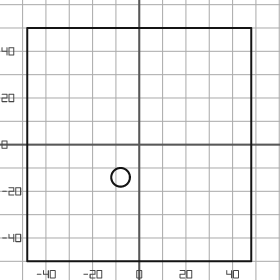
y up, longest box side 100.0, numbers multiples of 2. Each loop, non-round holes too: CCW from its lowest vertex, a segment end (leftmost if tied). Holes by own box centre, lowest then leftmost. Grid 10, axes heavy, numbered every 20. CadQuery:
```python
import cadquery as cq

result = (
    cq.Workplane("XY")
    .moveTo(-48.0, -50.0)
    .lineTo(48.0, -50.0)
    .lineTo(48.0, 50.0)
    .lineTo(-48.0, 50.0)
    .close()
    .moveTo(-8.0, -14.0)
    .circle(4.0)
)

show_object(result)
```